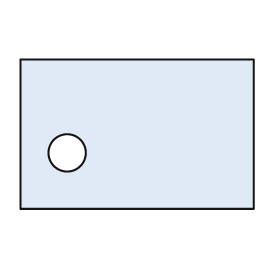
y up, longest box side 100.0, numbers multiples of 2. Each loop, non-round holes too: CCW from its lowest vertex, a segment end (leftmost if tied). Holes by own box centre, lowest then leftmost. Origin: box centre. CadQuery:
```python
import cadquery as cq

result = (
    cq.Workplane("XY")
    .moveTo(-50.0, -32.0)
    .lineTo(50.0, -32.0)
    .lineTo(50.0, 32.0)
    .lineTo(-50.0, 32.0)
    .close()
    .moveTo(-30.0, -8.0)
    .circle(8.0)
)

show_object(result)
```